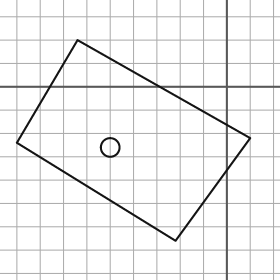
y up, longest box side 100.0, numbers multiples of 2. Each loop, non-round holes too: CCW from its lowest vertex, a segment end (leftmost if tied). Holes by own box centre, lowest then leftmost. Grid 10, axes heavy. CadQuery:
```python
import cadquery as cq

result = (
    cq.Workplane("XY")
    .moveTo(-22.0, -66.0)
    .lineTo(10.0, -22.0)
    .lineTo(-64.0, 20.0)
    .lineTo(-90.0, -24.0)
    .close()
    .moveTo(-50.0, -26.0)
    .circle(4.0)
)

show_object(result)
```